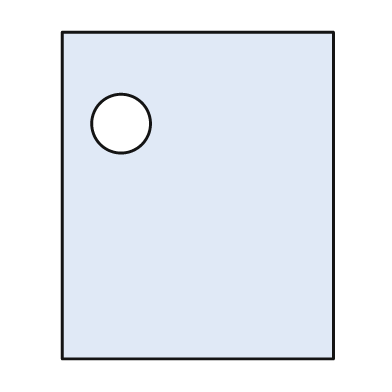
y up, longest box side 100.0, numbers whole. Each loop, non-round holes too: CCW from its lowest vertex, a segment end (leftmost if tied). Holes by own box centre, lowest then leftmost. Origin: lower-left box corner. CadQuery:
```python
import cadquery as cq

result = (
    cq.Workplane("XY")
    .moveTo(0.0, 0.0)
    .lineTo(83.0, 0.0)
    .lineTo(83.0, 100.0)
    .lineTo(0.0, 100.0)
    .close()
    .moveTo(18.0, 72.0)
    .circle(9.0)
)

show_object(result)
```